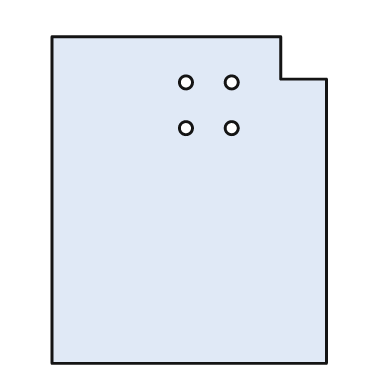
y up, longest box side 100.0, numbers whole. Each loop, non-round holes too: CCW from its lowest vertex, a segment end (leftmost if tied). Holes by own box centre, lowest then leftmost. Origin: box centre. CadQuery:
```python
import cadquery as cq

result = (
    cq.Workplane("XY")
    .moveTo(-42.0, -50.0)
    .lineTo(42.0, -50.0)
    .lineTo(42.0, 37.0)
    .lineTo(28.0, 37.0)
    .lineTo(28.0, 50.0)
    .lineTo(-42.0, 50.0)
    .close()
    .moveTo(-1.0, 22.0)
    .circle(2.0)
    .moveTo(13.0, 22.0)
    .circle(2.0)
    .moveTo(-1.0, 36.0)
    .circle(2.0)
    .moveTo(13.0, 36.0)
    .circle(2.0)
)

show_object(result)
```